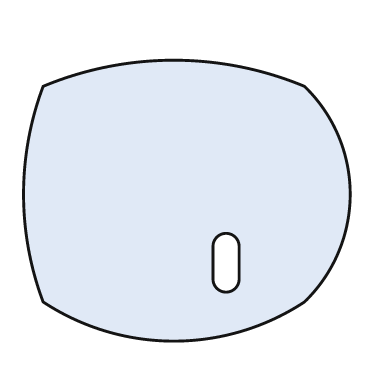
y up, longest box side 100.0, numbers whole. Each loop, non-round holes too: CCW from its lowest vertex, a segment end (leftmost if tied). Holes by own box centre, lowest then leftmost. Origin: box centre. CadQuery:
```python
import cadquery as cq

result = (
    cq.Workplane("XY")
    .moveTo(-44.0, -31.0)
    .threePointArc((-4.0, -43.0), (36.0, -31.0))
    .threePointArc((50.0, 2.0), (36.0, 35.0))
    .threePointArc((-4.0, 43.0), (-44.0, 35.0))
    .threePointArc((-50.0, 2.0), (-44.0, -31.0))
    .close()
    .moveTo(8.0, -24.0)
    .threePointArc((12.0, -28.0), (16.0, -24.0))
    .lineTo(16.0, -14.0)
    .threePointArc((12.0, -10.0), (8.0, -14.0))
    .close()
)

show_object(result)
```